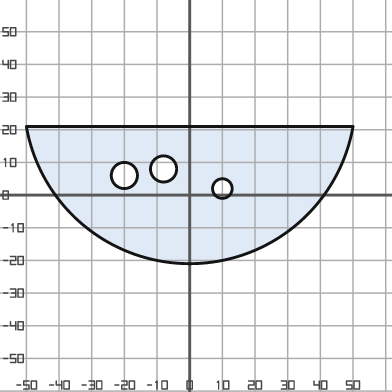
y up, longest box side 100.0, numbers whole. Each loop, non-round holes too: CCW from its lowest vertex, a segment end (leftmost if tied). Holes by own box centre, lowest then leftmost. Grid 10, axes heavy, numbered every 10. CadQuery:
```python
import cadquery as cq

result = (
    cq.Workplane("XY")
    .moveTo(-50.0, 21.0)
    .threePointArc((0.0, -21.0), (50.0, 21.0))
    .close()
    .moveTo(10.0, 2.0)
    .circle(3.0)
    .moveTo(-20.0, 6.0)
    .circle(4.0)
    .moveTo(-8.0, 8.0)
    .circle(4.0)
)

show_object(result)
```